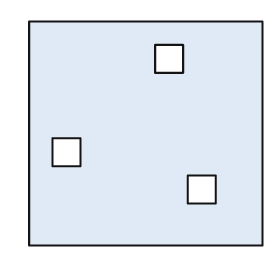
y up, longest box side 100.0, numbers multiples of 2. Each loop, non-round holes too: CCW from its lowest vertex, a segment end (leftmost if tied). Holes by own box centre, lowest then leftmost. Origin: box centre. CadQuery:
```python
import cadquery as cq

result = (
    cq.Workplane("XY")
    .moveTo(-50.0, -48.0)
    .lineTo(50.0, -48.0)
    .lineTo(50.0, 48.0)
    .lineTo(-50.0, 48.0)
    .close()
    .moveTo(18.0, -30.0)
    .lineTo(30.0, -30.0)
    .lineTo(30.0, -18.0)
    .lineTo(18.0, -18.0)
    .close()
    .moveTo(-40.0, -14.0)
    .lineTo(-28.0, -14.0)
    .lineTo(-28.0, -2.0)
    .lineTo(-40.0, -2.0)
    .close()
    .moveTo(4.0, 26.0)
    .lineTo(16.0, 26.0)
    .lineTo(16.0, 38.0)
    .lineTo(4.0, 38.0)
    .close()
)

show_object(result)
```